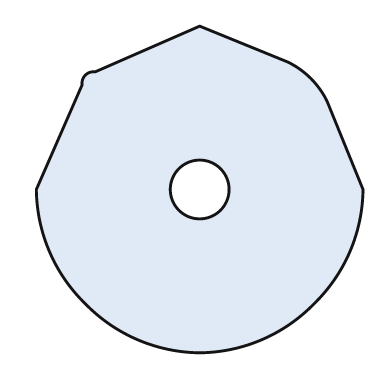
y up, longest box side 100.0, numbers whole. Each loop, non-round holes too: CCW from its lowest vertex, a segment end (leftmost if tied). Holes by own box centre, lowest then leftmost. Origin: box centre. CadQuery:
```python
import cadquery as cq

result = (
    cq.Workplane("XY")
    .moveTo(0.0, -50.0)
    .threePointArc((19.0, -46.0), (35.0, -35.0))
    .threePointArc((46.0, -19.0), (50.0, 0.0))
    .lineTo(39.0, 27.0)
    .threePointArc((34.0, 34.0), (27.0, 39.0))
    .lineTo(0.0, 50.0)
    .lineTo(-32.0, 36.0)
    .threePointArc((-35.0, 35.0), (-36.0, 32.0))
    .lineTo(-50.0, 0.0)
    .threePointArc((-46.0, -19.0), (-35.0, -35.0))
    .threePointArc((-19.0, -46.0), (0.0, -50.0))
    .close()
    .moveTo(0.0, 0.0)
    .circle(9.0)
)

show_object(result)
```